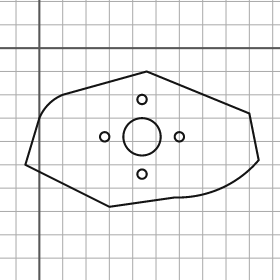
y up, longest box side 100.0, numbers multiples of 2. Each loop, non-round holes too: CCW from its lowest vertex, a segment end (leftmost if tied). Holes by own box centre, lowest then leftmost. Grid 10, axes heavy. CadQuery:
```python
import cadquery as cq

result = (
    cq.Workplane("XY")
    .moveTo(30.0, -68.0)
    .lineTo(58.0, -64.0)
    .threePointArc((78.0, -60.0), (94.0, -48.0))
    .lineTo(90.0, -28.0)
    .lineTo(46.0, -10.0)
    .lineTo(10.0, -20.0)
    .threePointArc((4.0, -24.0), (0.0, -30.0))
    .lineTo(-6.0, -50.0)
    .close()
    .moveTo(44.0, -54.0)
    .circle(2.0)
    .moveTo(28.0, -38.0)
    .circle(2.0)
    .moveTo(44.0, -38.0)
    .circle(8.0)
    .moveTo(60.0, -38.0)
    .circle(2.0)
    .moveTo(44.0, -22.0)
    .circle(2.0)
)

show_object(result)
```